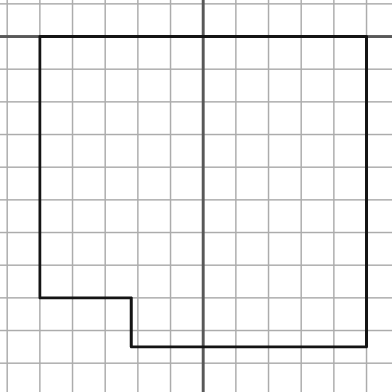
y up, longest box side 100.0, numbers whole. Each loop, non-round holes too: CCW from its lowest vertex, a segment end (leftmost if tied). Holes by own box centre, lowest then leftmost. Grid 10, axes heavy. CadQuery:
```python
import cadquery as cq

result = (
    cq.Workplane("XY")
    .moveTo(-22.0, -95.0)
    .lineTo(50.0, -95.0)
    .lineTo(50.0, 0.0)
    .lineTo(-50.0, 0.0)
    .lineTo(-50.0, -80.0)
    .lineTo(-22.0, -80.0)
    .close()
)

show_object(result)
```